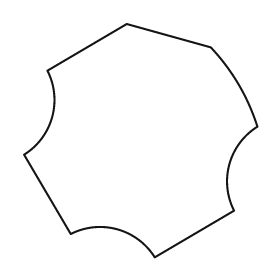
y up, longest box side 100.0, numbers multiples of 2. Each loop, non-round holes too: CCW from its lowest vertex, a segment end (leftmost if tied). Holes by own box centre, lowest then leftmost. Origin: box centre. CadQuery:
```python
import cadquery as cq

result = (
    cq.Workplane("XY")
    .moveTo(6.0, -50.0)
    .lineTo(40.0, -30.0)
    .threePointArc((38.0, -10.0), (50.0, 6.0))
    .threePointArc((42.0, 24.0), (30.0, 40.0))
    .lineTo(-6.0, 50.0)
    .lineTo(-40.0, 30.0)
    .threePointArc((-38.0, 10.0), (-50.0, -6.0))
    .lineTo(-30.0, -40.0)
    .threePointArc((-10.0, -38.0), (6.0, -50.0))
    .close()
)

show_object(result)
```